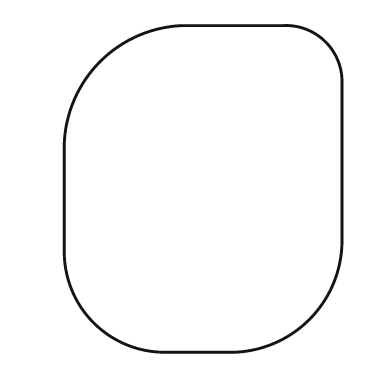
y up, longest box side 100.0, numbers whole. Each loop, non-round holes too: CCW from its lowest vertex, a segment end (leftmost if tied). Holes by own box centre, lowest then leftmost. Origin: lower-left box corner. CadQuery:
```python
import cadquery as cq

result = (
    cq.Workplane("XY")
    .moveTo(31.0, 0.0)
    .lineTo(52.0, 0.0)
    .threePointArc((75.0, 10.0), (85.0, 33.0))
    .lineTo(85.0, 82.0)
    .threePointArc((80.0, 95.0), (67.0, 100.0))
    .lineTo(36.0, 100.0)
    .threePointArc((11.0, 89.0), (0.0, 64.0))
    .lineTo(0.0, 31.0)
    .threePointArc((9.0, 9.0), (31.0, 0.0))
    .close()
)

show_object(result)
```